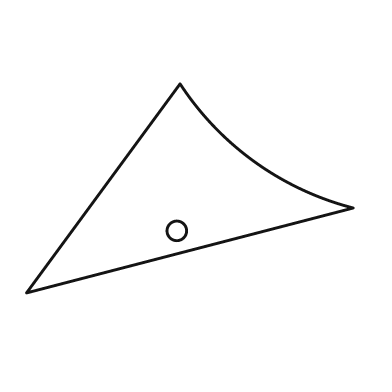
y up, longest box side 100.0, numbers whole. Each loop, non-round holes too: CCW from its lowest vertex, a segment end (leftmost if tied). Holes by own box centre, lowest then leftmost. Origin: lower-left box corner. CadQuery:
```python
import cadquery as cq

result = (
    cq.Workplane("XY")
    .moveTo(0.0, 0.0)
    .lineTo(100.0, 26.0)
    .threePointArc((70.0, 40.0), (47.0, 64.0))
    .close()
    .moveTo(46.0, 19.0)
    .circle(3.0)
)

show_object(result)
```